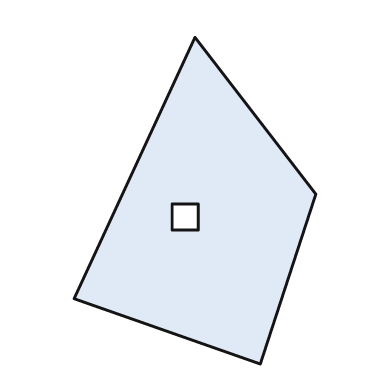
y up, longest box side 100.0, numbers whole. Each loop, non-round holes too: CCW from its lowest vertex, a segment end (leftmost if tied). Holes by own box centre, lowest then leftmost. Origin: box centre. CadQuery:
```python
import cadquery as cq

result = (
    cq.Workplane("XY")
    .moveTo(20.0, -50.0)
    .lineTo(37.0, 2.0)
    .lineTo(0.0, 50.0)
    .lineTo(-37.0, -30.0)
    .close()
    .moveTo(-7.0, -9.0)
    .lineTo(1.0, -9.0)
    .lineTo(1.0, -1.0)
    .lineTo(-7.0, -1.0)
    .close()
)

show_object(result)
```